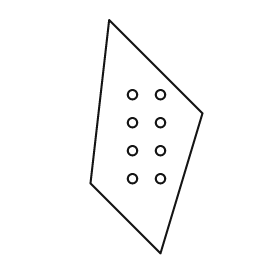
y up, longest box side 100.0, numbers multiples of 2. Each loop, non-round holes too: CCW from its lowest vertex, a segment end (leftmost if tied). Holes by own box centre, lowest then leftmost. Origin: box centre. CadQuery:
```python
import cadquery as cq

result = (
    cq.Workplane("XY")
    .moveTo(6.0, -50.0)
    .lineTo(24.0, 10.0)
    .lineTo(-16.0, 50.0)
    .lineTo(-24.0, -20.0)
    .close()
    .moveTo(-6.0, -18.0)
    .circle(2.0)
    .moveTo(6.0, -18.0)
    .circle(2.0)
    .moveTo(-6.0, -6.0)
    .circle(2.0)
    .moveTo(6.0, -6.0)
    .circle(2.0)
    .moveTo(-6.0, 6.0)
    .circle(2.0)
    .moveTo(6.0, 6.0)
    .circle(2.0)
    .moveTo(-6.0, 18.0)
    .circle(2.0)
    .moveTo(6.0, 18.0)
    .circle(2.0)
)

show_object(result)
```